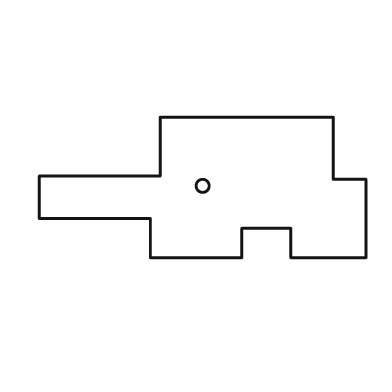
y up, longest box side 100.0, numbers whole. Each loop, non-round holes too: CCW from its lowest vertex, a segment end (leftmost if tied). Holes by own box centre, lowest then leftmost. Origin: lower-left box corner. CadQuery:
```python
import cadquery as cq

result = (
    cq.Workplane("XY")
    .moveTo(34.0, 0.0)
    .lineTo(62.0, 0.0)
    .lineTo(62.0, 9.0)
    .lineTo(77.0, 9.0)
    .lineTo(77.0, 0.0)
    .lineTo(100.0, 0.0)
    .lineTo(100.0, 24.0)
    .lineTo(90.0, 24.0)
    .lineTo(90.0, 43.0)
    .lineTo(37.0, 43.0)
    .lineTo(37.0, 25.0)
    .lineTo(0.0, 25.0)
    .lineTo(0.0, 12.0)
    .lineTo(34.0, 12.0)
    .close()
    .moveTo(50.0, 22.0)
    .circle(2.0)
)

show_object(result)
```